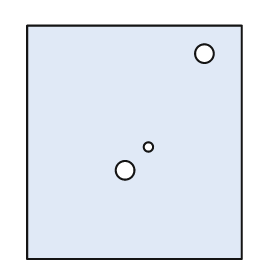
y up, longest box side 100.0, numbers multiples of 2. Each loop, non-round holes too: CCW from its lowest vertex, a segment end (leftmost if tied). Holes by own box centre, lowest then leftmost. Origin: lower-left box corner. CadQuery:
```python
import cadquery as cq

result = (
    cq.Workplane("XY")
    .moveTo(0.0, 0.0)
    .lineTo(92.0, 0.0)
    .lineTo(92.0, 100.0)
    .lineTo(0.0, 100.0)
    .close()
    .moveTo(42.0, 38.0)
    .circle(4.0)
    .moveTo(52.0, 48.0)
    .circle(2.0)
    .moveTo(76.0, 88.0)
    .circle(4.0)
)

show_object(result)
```